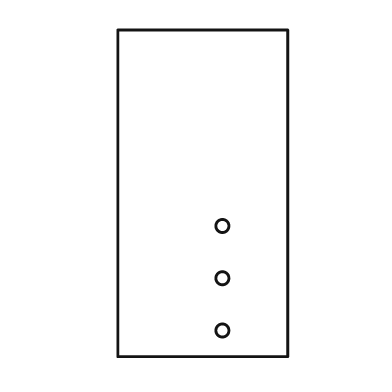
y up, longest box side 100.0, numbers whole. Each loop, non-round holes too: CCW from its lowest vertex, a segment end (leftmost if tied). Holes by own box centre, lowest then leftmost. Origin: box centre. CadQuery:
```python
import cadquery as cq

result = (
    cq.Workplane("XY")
    .moveTo(-26.0, -50.0)
    .lineTo(26.0, -50.0)
    .lineTo(26.0, 50.0)
    .lineTo(-26.0, 50.0)
    .close()
    .moveTo(6.0, -42.0)
    .circle(2.0)
    .moveTo(6.0, -26.0)
    .circle(2.0)
    .moveTo(6.0, -10.0)
    .circle(2.0)
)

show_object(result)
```